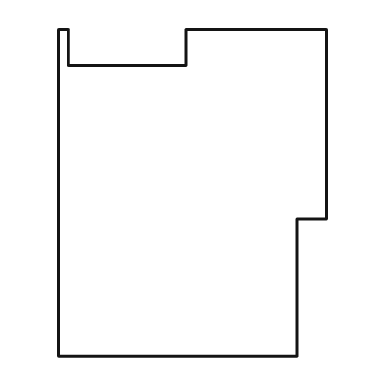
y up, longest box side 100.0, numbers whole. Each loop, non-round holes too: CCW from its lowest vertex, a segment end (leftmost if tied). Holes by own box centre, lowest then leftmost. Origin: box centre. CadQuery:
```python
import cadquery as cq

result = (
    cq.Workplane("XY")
    .moveTo(-41.0, -50.0)
    .lineTo(32.0, -50.0)
    .lineTo(32.0, -8.0)
    .lineTo(41.0, -8.0)
    .lineTo(41.0, 50.0)
    .lineTo(-2.0, 50.0)
    .lineTo(-2.0, 39.0)
    .lineTo(-38.0, 39.0)
    .lineTo(-38.0, 50.0)
    .lineTo(-41.0, 50.0)
    .close()
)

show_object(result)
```